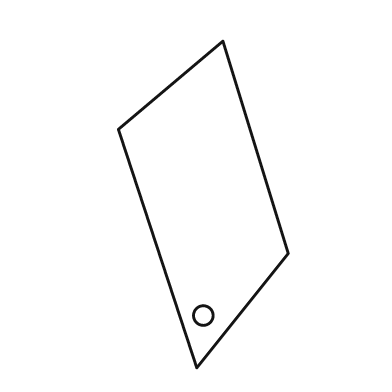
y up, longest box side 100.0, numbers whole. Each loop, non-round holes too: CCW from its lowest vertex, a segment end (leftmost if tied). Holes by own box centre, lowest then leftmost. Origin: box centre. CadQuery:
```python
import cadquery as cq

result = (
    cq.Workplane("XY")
    .moveTo(-2.0, -50.0)
    .lineTo(26.0, -15.0)
    .lineTo(6.0, 50.0)
    .lineTo(-26.0, 23.0)
    .close()
    .moveTo(0.0, -34.0)
    .circle(3.0)
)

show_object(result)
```